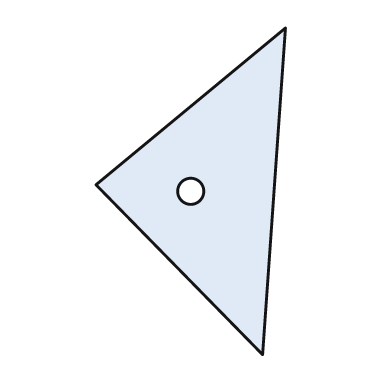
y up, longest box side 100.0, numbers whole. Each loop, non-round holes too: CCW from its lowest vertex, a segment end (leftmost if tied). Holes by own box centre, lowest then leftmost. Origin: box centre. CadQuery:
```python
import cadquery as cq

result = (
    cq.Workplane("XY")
    .moveTo(22.0, -50.0)
    .lineTo(29.0, 50.0)
    .lineTo(-29.0, 2.0)
    .close()
    .moveTo(0.0, 0.0)
    .circle(4.0)
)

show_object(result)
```